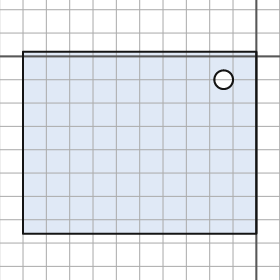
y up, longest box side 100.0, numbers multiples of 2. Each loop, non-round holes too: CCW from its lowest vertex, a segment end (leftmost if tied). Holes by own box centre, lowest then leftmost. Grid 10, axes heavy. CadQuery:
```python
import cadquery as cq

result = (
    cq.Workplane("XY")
    .moveTo(-100.0, -76.0)
    .lineTo(0.0, -76.0)
    .lineTo(0.0, 2.0)
    .lineTo(-100.0, 2.0)
    .close()
    .moveTo(-14.0, -10.0)
    .circle(4.0)
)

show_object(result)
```